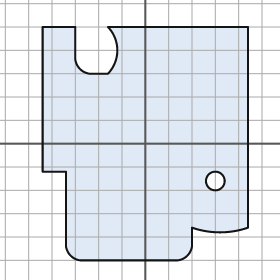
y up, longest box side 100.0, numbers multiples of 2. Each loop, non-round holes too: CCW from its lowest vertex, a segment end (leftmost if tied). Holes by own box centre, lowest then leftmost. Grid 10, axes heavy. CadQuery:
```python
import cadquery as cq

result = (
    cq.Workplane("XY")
    .moveTo(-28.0, -50.0)
    .lineTo(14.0, -50.0)
    .threePointArc((18.0, -48.0), (20.0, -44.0))
    .lineTo(20.0, -36.0)
    .threePointArc((32.0, -38.0), (44.0, -36.0))
    .lineTo(44.0, 50.0)
    .lineTo(-16.0, 50.0)
    .threePointArc((-12.0, 40.0), (-16.0, 30.0))
    .lineTo(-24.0, 30.0)
    .threePointArc((-28.0, 32.0), (-30.0, 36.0))
    .lineTo(-30.0, 50.0)
    .lineTo(-44.0, 50.0)
    .lineTo(-44.0, -12.0)
    .lineTo(-34.0, -12.0)
    .lineTo(-34.0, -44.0)
    .threePointArc((-32.0, -48.0), (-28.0, -50.0))
    .close()
    .moveTo(30.0, -16.0)
    .circle(4.0)
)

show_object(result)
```